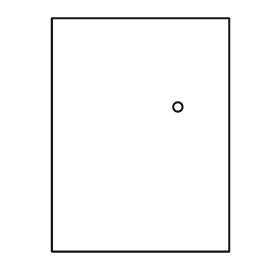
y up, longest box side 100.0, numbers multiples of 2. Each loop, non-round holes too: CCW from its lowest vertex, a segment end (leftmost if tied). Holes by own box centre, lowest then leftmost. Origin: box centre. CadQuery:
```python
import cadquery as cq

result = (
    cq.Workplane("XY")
    .moveTo(-38.0, -50.0)
    .lineTo(38.0, -50.0)
    .lineTo(38.0, 50.0)
    .lineTo(-38.0, 50.0)
    .close()
    .moveTo(16.0, 12.0)
    .circle(2.0)
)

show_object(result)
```